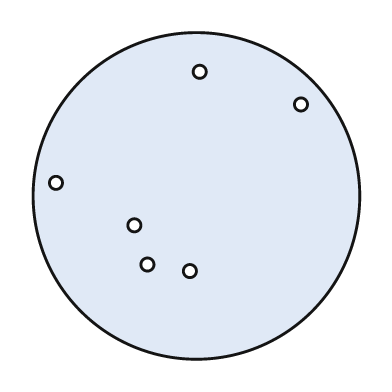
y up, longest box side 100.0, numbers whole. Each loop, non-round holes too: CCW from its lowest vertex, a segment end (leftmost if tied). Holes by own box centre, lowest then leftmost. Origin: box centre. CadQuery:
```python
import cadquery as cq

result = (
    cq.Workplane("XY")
    .moveTo(0.0, 0.0)
    .circle(50.0)
    .moveTo(-2.0, -23.0)
    .circle(2.0)
    .moveTo(-15.0, -21.0)
    .circle(2.0)
    .moveTo(-19.0, -9.0)
    .circle(2.0)
    .moveTo(-43.0, 4.0)
    .circle(2.0)
    .moveTo(32.0, 28.0)
    .circle(2.0)
    .moveTo(1.0, 38.0)
    .circle(2.0)
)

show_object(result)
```